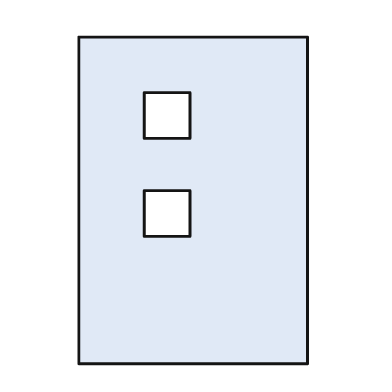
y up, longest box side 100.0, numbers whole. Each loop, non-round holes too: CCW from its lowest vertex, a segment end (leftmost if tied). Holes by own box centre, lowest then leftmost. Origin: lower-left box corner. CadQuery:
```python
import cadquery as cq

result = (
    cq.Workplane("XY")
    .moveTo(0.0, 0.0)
    .lineTo(70.0, 0.0)
    .lineTo(70.0, 100.0)
    .lineTo(0.0, 100.0)
    .close()
    .moveTo(20.0, 39.0)
    .lineTo(34.0, 39.0)
    .lineTo(34.0, 53.0)
    .lineTo(20.0, 53.0)
    .close()
    .moveTo(20.0, 69.0)
    .lineTo(34.0, 69.0)
    .lineTo(34.0, 83.0)
    .lineTo(20.0, 83.0)
    .close()
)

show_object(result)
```